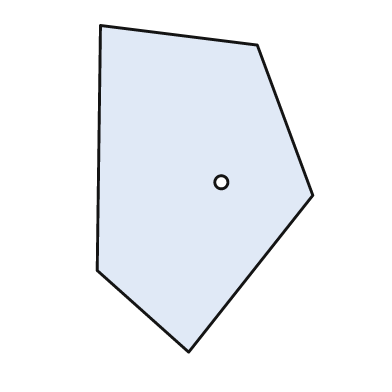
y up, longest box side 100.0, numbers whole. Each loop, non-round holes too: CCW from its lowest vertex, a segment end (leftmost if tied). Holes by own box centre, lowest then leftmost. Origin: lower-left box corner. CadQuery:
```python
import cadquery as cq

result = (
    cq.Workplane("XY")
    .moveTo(28.0, 0.0)
    .lineTo(66.0, 48.0)
    .lineTo(49.0, 94.0)
    .lineTo(1.0, 100.0)
    .lineTo(0.0, 25.0)
    .close()
    .moveTo(38.0, 52.0)
    .circle(2.0)
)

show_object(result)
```